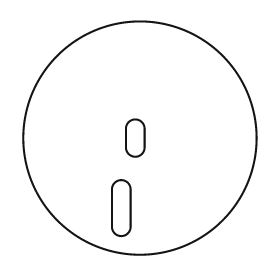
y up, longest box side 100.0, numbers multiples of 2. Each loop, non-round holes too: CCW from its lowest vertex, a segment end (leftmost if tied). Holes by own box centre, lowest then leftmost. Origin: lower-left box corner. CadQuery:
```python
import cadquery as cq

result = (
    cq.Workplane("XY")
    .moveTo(50.0, 50.0)
    .circle(50.0)
    .moveTo(38.0, 12.0)
    .threePointArc((42.0, 8.0), (46.0, 12.0))
    .lineTo(46.0, 28.0)
    .threePointArc((42.0, 32.0), (38.0, 28.0))
    .close()
    .moveTo(44.0, 46.0)
    .threePointArc((48.0, 42.0), (52.0, 46.0))
    .lineTo(52.0, 54.0)
    .threePointArc((48.0, 58.0), (44.0, 54.0))
    .close()
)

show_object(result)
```